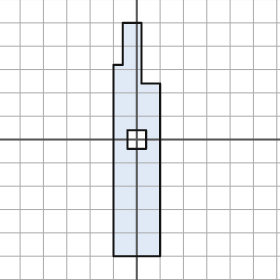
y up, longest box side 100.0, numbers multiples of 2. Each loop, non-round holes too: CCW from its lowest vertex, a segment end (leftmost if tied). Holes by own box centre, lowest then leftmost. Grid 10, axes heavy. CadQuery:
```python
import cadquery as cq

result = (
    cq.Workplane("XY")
    .moveTo(-10.0, -50.0)
    .lineTo(10.0, -50.0)
    .lineTo(10.0, 24.0)
    .lineTo(2.0, 24.0)
    .lineTo(2.0, 50.0)
    .lineTo(-6.0, 50.0)
    .lineTo(-6.0, 32.0)
    .lineTo(-10.0, 32.0)
    .close()
    .moveTo(-4.0, -4.0)
    .lineTo(4.0, -4.0)
    .lineTo(4.0, 4.0)
    .lineTo(-4.0, 4.0)
    .close()
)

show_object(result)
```